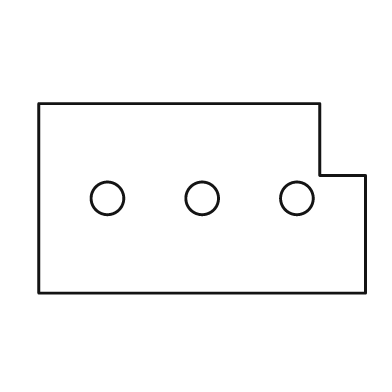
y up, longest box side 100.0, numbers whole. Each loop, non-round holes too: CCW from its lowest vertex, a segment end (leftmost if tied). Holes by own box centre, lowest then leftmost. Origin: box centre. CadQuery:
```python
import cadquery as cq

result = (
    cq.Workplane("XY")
    .moveTo(-50.0, -29.0)
    .lineTo(50.0, -29.0)
    .lineTo(50.0, 7.0)
    .lineTo(36.0, 7.0)
    .lineTo(36.0, 29.0)
    .lineTo(-50.0, 29.0)
    .close()
    .moveTo(-29.0, 0.0)
    .circle(5.0)
    .moveTo(0.0, 0.0)
    .circle(5.0)
    .moveTo(29.0, 0.0)
    .circle(5.0)
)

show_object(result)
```